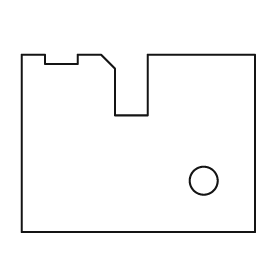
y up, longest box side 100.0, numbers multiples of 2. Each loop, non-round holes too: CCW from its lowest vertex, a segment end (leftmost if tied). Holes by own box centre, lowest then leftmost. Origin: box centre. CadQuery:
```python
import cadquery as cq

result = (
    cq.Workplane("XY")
    .moveTo(-50.0, -38.0)
    .lineTo(50.0, -38.0)
    .lineTo(50.0, 38.0)
    .lineTo(4.0, 38.0)
    .lineTo(4.0, 12.0)
    .lineTo(-10.0, 12.0)
    .lineTo(-10.0, 32.0)
    .lineTo(-16.0, 38.0)
    .lineTo(-26.0, 38.0)
    .lineTo(-26.0, 34.0)
    .lineTo(-40.0, 34.0)
    .lineTo(-40.0, 38.0)
    .lineTo(-50.0, 38.0)
    .close()
    .moveTo(28.0, -16.0)
    .circle(6.0)
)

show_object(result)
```